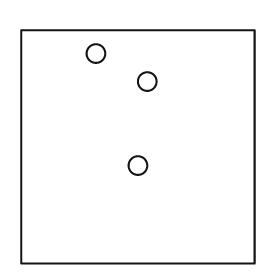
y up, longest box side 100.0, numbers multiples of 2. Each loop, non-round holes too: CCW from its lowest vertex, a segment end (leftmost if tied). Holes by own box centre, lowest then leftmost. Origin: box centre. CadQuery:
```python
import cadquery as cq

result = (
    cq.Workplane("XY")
    .moveTo(-50.0, -50.0)
    .lineTo(50.0, -50.0)
    .lineTo(50.0, 50.0)
    .lineTo(-50.0, 50.0)
    .close()
    .moveTo(0.0, -8.0)
    .circle(4.0)
    .moveTo(4.0, 28.0)
    .circle(4.0)
    .moveTo(-18.0, 40.0)
    .circle(4.0)
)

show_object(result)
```